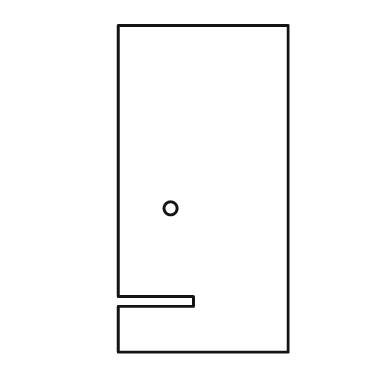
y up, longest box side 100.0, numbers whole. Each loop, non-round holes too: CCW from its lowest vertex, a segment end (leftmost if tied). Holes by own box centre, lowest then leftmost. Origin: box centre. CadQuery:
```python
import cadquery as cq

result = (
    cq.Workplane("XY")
    .moveTo(-26.0, -50.0)
    .lineTo(26.0, -50.0)
    .lineTo(26.0, 50.0)
    .lineTo(-26.0, 50.0)
    .lineTo(-26.0, -33.0)
    .lineTo(-3.0, -33.0)
    .lineTo(-3.0, -36.0)
    .lineTo(-26.0, -36.0)
    .close()
    .moveTo(-10.0, -6.0)
    .circle(2.0)
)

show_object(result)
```